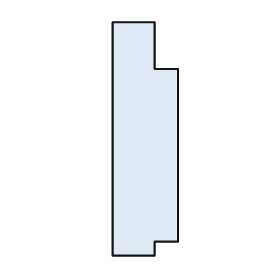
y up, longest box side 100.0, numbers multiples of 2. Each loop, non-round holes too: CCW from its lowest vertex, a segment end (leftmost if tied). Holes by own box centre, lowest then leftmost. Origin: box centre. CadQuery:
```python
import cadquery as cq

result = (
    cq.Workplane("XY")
    .moveTo(-14.0, -50.0)
    .lineTo(4.0, -50.0)
    .lineTo(4.0, -44.0)
    .lineTo(14.0, -44.0)
    .lineTo(14.0, 30.0)
    .lineTo(4.0, 30.0)
    .lineTo(4.0, 50.0)
    .lineTo(-14.0, 50.0)
    .close()
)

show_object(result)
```